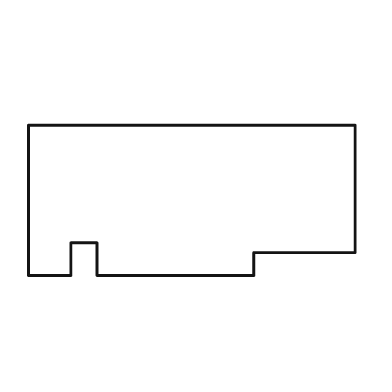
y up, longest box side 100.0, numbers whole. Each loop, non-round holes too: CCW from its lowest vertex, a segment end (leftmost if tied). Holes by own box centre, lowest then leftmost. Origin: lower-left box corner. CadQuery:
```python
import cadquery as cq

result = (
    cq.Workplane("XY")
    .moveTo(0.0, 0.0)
    .lineTo(13.0, 0.0)
    .lineTo(13.0, 10.0)
    .lineTo(21.0, 10.0)
    .lineTo(21.0, 0.0)
    .lineTo(69.0, 0.0)
    .lineTo(69.0, 7.0)
    .lineTo(100.0, 7.0)
    .lineTo(100.0, 46.0)
    .lineTo(0.0, 46.0)
    .close()
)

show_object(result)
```